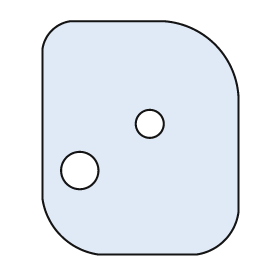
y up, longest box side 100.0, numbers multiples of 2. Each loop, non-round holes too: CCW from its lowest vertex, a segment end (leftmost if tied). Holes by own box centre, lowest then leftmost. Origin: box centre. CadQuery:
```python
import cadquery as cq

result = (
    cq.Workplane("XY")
    .moveTo(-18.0, -50.0)
    .lineTo(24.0, -50.0)
    .threePointArc((36.0, -44.0), (42.0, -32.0))
    .lineTo(42.0, 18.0)
    .threePointArc((32.0, 40.0), (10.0, 50.0))
    .lineTo(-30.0, 50.0)
    .threePointArc((-38.0, 46.0), (-42.0, 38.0))
    .lineTo(-42.0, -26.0)
    .threePointArc((-34.0, -42.0), (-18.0, -50.0))
    .close()
    .moveTo(-26.0, -14.0)
    .circle(8.0)
    .moveTo(4.0, 6.0)
    .circle(6.0)
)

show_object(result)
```